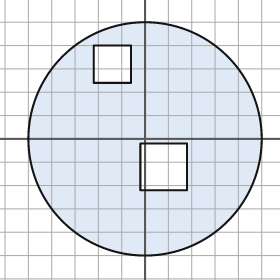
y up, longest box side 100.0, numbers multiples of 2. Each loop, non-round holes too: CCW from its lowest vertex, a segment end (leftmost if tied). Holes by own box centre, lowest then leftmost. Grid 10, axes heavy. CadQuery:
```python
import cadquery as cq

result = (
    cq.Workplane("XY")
    .moveTo(0.0, 0.0)
    .circle(50.0)
    .moveTo(-2.0, -22.0)
    .lineTo(18.0, -22.0)
    .lineTo(18.0, -2.0)
    .lineTo(-2.0, -2.0)
    .close()
    .moveTo(-22.0, 24.0)
    .lineTo(-6.0, 24.0)
    .lineTo(-6.0, 40.0)
    .lineTo(-22.0, 40.0)
    .close()
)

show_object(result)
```